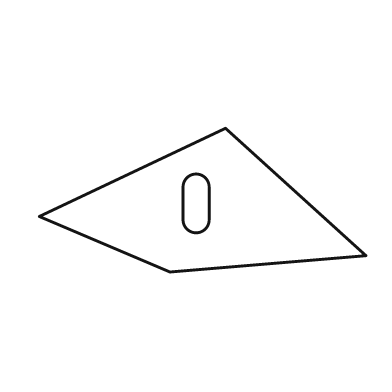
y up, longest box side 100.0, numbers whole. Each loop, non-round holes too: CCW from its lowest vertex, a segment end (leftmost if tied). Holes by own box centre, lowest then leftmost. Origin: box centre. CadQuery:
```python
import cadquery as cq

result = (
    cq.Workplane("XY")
    .moveTo(-10.0, -22.0)
    .lineTo(50.0, -17.0)
    .lineTo(7.0, 22.0)
    .lineTo(-50.0, -5.0)
    .close()
    .moveTo(-6.0, -6.0)
    .threePointArc((-2.0, -10.0), (2.0, -6.0))
    .lineTo(2.0, 4.0)
    .threePointArc((-2.0, 8.0), (-6.0, 4.0))
    .close()
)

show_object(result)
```